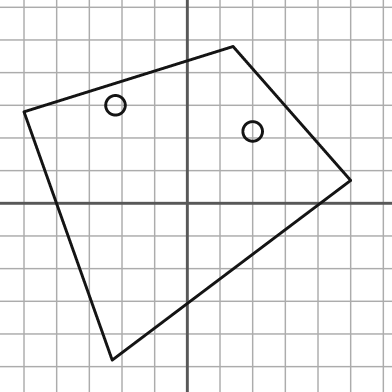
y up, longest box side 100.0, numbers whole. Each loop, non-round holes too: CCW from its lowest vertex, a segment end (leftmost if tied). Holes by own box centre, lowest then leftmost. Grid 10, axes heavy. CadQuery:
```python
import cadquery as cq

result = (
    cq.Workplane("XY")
    .moveTo(-23.0, -48.0)
    .lineTo(50.0, 7.0)
    .lineTo(14.0, 48.0)
    .lineTo(-50.0, 28.0)
    .close()
    .moveTo(20.0, 22.0)
    .circle(3.0)
    .moveTo(-22.0, 30.0)
    .circle(3.0)
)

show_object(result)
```